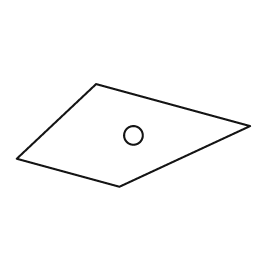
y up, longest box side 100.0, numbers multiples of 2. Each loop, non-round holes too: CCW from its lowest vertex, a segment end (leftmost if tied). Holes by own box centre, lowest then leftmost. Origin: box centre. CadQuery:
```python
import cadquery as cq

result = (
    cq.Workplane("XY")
    .moveTo(-6.0, -22.0)
    .lineTo(50.0, 4.0)
    .lineTo(-16.0, 22.0)
    .lineTo(-50.0, -10.0)
    .close()
    .moveTo(0.0, 0.0)
    .circle(4.0)
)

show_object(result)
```